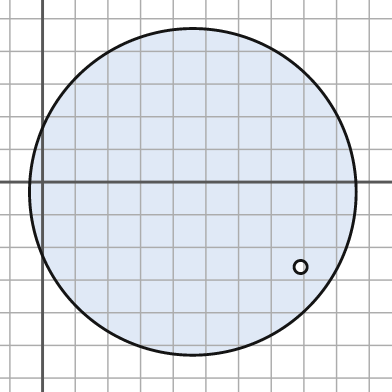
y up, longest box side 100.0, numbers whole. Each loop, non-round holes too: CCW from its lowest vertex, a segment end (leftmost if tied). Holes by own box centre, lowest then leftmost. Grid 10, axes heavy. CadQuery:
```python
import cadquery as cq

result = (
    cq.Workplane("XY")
    .moveTo(46.0, -3.0)
    .circle(50.0)
    .moveTo(79.0, -26.0)
    .circle(2.0)
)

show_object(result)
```